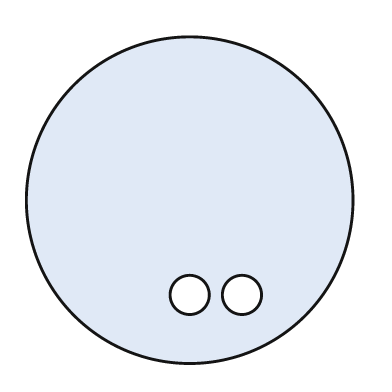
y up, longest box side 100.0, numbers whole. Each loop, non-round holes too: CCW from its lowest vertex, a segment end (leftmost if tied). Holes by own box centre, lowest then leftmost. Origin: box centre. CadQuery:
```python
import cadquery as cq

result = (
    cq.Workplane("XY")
    .moveTo(0.0, 0.0)
    .circle(50.0)
    .moveTo(0.0, -29.0)
    .circle(6.0)
    .moveTo(16.0, -29.0)
    .circle(6.0)
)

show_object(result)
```